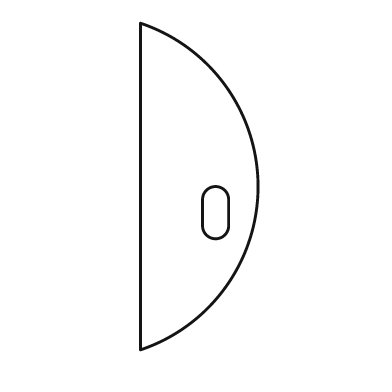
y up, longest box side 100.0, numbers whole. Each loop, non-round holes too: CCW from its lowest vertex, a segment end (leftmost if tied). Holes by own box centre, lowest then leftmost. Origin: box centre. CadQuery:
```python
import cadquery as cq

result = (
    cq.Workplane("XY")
    .moveTo(-18.0, -50.0)
    .threePointArc((18.0, 0.0), (-18.0, 50.0))
    .close()
    .moveTo(1.0, -12.0)
    .threePointArc((5.0, -16.0), (9.0, -12.0))
    .lineTo(9.0, -4.0)
    .threePointArc((5.0, 0.0), (1.0, -4.0))
    .close()
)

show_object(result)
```